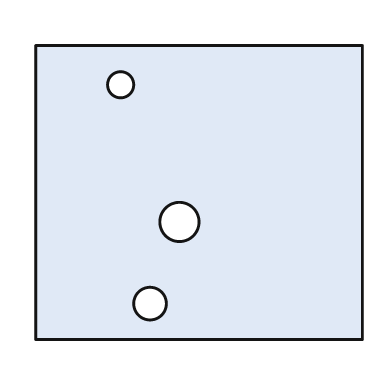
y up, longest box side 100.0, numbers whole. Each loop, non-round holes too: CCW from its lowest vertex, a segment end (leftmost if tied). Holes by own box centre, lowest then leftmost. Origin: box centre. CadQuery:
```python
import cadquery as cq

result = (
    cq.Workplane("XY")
    .moveTo(-50.0, -45.0)
    .lineTo(50.0, -45.0)
    .lineTo(50.0, 45.0)
    .lineTo(-50.0, 45.0)
    .close()
    .moveTo(-15.0, -34.0)
    .circle(5.0)
    .moveTo(-6.0, -9.0)
    .circle(6.0)
    .moveTo(-24.0, 33.0)
    .circle(4.0)
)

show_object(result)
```